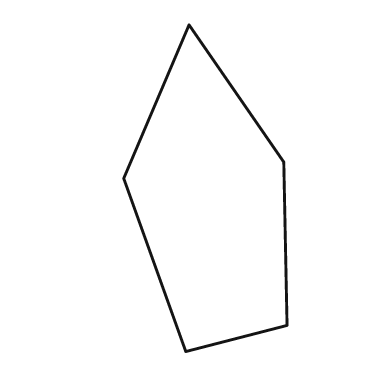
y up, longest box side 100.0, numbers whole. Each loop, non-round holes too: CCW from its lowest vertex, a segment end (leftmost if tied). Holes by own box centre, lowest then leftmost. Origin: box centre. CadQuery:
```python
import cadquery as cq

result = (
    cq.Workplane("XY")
    .moveTo(-6.0, -50.0)
    .lineTo(25.0, -42.0)
    .lineTo(24.0, 8.0)
    .lineTo(-5.0, 50.0)
    .lineTo(-25.0, 3.0)
    .close()
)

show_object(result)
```